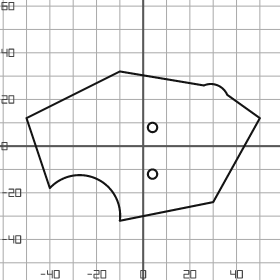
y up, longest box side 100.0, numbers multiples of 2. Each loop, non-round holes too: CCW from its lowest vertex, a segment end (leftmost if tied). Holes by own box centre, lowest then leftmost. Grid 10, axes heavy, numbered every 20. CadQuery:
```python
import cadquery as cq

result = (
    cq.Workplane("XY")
    .moveTo(-10.0, -32.0)
    .lineTo(30.0, -24.0)
    .lineTo(50.0, 12.0)
    .lineTo(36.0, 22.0)
    .threePointArc((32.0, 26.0), (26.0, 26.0))
    .lineTo(-10.0, 32.0)
    .lineTo(-50.0, 12.0)
    .lineTo(-40.0, -18.0)
    .threePointArc((-20.0, -14.0), (-10.0, -32.0))
    .close()
    .moveTo(4.0, -12.0)
    .circle(2.0)
    .moveTo(4.0, 8.0)
    .circle(2.0)
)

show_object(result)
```